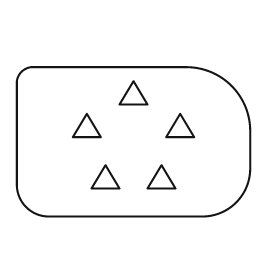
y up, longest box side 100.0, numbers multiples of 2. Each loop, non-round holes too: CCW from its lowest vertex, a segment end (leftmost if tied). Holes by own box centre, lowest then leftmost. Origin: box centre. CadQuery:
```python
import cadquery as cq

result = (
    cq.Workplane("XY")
    .moveTo(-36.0, -32.0)
    .lineTo(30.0, -32.0)
    .threePointArc((44.0, -26.0), (50.0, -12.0))
    .lineTo(50.0, 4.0)
    .threePointArc((42.0, 24.0), (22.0, 32.0))
    .lineTo(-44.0, 32.0)
    .threePointArc((-48.0, 30.0), (-50.0, 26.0))
    .lineTo(-50.0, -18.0)
    .threePointArc((-46.0, -28.0), (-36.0, -32.0))
    .close()
    .moveTo(-18.0, -20.0)
    .lineTo(-6.0, -20.0)
    .lineTo(-12.0, -10.0)
    .close()
    .moveTo(6.0, -20.0)
    .lineTo(18.0, -20.0)
    .lineTo(12.0, -10.0)
    .close()
    .moveTo(-26.0, 2.0)
    .lineTo(-14.0, 2.0)
    .lineTo(-20.0, 12.0)
    .close()
    .moveTo(14.0, 2.0)
    .lineTo(26.0, 2.0)
    .lineTo(20.0, 12.0)
    .close()
    .moveTo(-6.0, 16.0)
    .lineTo(6.0, 16.0)
    .lineTo(0.0, 26.0)
    .close()
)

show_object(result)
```